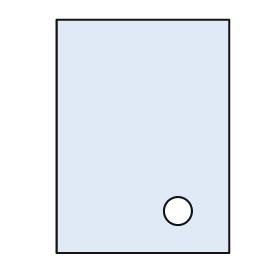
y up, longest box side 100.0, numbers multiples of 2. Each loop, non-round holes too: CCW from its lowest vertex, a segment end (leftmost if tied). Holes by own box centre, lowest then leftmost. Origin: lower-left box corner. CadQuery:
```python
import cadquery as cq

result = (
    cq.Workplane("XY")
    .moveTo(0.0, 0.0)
    .lineTo(74.0, 0.0)
    .lineTo(74.0, 100.0)
    .lineTo(0.0, 100.0)
    .close()
    .moveTo(52.0, 18.0)
    .circle(6.0)
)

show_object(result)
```